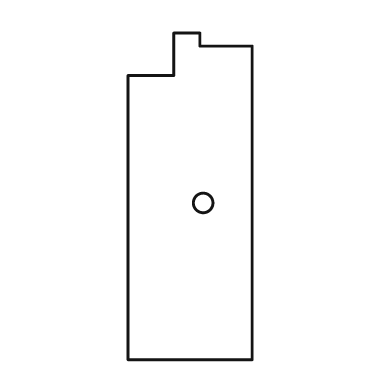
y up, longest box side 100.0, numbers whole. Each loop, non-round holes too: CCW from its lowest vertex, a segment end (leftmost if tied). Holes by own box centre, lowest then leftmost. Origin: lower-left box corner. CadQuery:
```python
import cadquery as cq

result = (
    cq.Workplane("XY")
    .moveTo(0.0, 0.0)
    .lineTo(38.0, 0.0)
    .lineTo(38.0, 96.0)
    .lineTo(22.0, 96.0)
    .lineTo(22.0, 100.0)
    .lineTo(14.0, 100.0)
    .lineTo(14.0, 87.0)
    .lineTo(0.0, 87.0)
    .close()
    .moveTo(23.0, 48.0)
    .circle(3.0)
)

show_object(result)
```